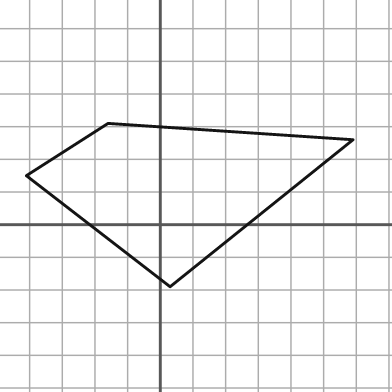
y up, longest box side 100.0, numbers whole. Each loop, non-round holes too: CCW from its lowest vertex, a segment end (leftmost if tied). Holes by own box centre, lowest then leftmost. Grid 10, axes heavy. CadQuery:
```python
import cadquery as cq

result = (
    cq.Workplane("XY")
    .moveTo(3.0, -19.0)
    .lineTo(59.0, 26.0)
    .lineTo(-16.0, 31.0)
    .lineTo(-41.0, 15.0)
    .close()
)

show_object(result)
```